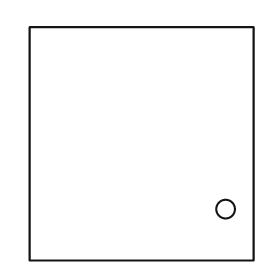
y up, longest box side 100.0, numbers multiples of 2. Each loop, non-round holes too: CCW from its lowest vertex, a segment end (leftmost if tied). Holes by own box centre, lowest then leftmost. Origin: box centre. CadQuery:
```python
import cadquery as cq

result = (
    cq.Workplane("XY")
    .moveTo(-48.0, -50.0)
    .lineTo(48.0, -50.0)
    .lineTo(48.0, 50.0)
    .lineTo(-48.0, 50.0)
    .close()
    .moveTo(36.0, -28.0)
    .circle(4.0)
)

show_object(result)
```